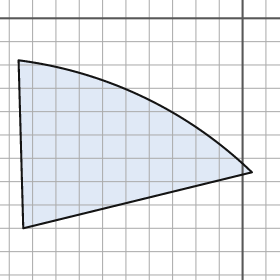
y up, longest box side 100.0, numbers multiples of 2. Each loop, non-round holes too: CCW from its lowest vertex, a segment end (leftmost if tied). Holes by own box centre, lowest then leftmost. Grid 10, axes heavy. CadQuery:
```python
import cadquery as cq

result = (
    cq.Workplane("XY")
    .moveTo(-94.0, -90.0)
    .lineTo(4.0, -66.0)
    .threePointArc((-42.0, -34.0), (-96.0, -18.0))
    .close()
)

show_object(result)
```